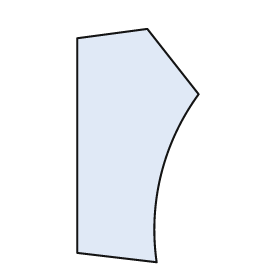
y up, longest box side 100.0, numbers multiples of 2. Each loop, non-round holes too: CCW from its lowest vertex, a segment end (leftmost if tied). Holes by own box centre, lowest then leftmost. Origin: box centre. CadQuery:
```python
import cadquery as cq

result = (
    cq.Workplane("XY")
    .moveTo(8.0, -50.0)
    .threePointArc((10.0, -12.0), (26.0, 22.0))
    .lineTo(4.0, 50.0)
    .lineTo(-26.0, 46.0)
    .lineTo(-26.0, -46.0)
    .close()
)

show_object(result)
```